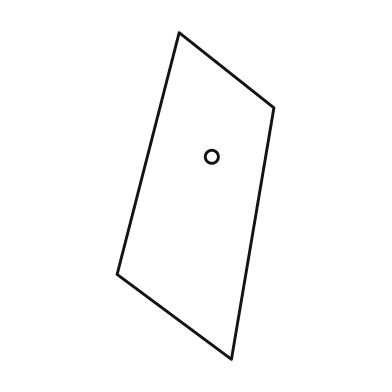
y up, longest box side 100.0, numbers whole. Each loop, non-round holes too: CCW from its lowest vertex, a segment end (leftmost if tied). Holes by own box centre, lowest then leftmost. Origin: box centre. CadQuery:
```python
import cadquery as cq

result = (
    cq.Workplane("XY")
    .moveTo(11.0, -50.0)
    .lineTo(24.0, 27.0)
    .lineTo(-5.0, 50.0)
    .lineTo(-24.0, -24.0)
    .close()
    .moveTo(5.0, 12.0)
    .circle(2.0)
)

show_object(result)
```